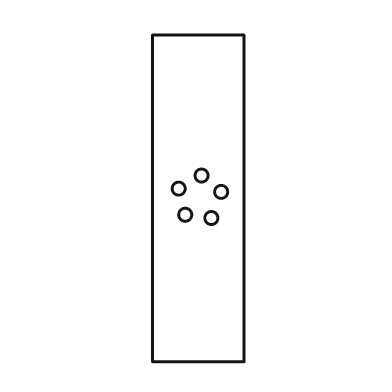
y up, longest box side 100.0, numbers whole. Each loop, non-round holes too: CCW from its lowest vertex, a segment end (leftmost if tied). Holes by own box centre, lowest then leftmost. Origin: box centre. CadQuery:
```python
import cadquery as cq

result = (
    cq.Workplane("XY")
    .moveTo(-14.0, -50.0)
    .lineTo(14.0, -50.0)
    .lineTo(14.0, 50.0)
    .lineTo(-14.0, 50.0)
    .close()
    .moveTo(4.0, -6.0)
    .circle(2.0)
    .moveTo(-4.0, -5.0)
    .circle(2.0)
    .moveTo(7.0, 2.0)
    .circle(2.0)
    .moveTo(-6.0, 3.0)
    .circle(2.0)
    .moveTo(1.0, 7.0)
    .circle(2.0)
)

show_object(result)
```